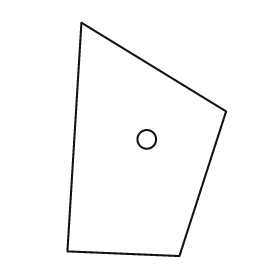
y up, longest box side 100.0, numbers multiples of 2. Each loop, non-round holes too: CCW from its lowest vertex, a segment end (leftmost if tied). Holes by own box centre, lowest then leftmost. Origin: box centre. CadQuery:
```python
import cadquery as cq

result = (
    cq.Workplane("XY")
    .moveTo(14.0, -50.0)
    .lineTo(34.0, 12.0)
    .lineTo(-28.0, 50.0)
    .lineTo(-34.0, -48.0)
    .close()
    .moveTo(0.0, 0.0)
    .circle(4.0)
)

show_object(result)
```